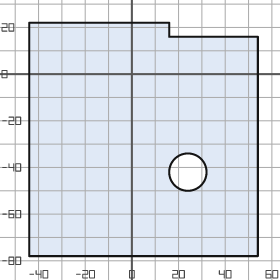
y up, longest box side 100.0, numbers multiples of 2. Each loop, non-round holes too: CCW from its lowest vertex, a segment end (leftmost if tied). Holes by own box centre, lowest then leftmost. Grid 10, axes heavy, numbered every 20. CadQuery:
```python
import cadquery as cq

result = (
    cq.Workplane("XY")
    .moveTo(-44.0, -78.0)
    .lineTo(54.0, -78.0)
    .lineTo(54.0, 16.0)
    .lineTo(16.0, 16.0)
    .lineTo(16.0, 22.0)
    .lineTo(-44.0, 22.0)
    .close()
    .moveTo(24.0, -42.0)
    .circle(8.0)
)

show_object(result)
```